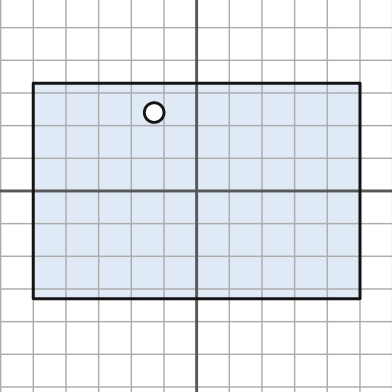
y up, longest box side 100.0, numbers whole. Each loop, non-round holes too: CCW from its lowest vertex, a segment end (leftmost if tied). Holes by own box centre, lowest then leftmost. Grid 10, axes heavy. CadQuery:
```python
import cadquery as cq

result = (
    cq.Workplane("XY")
    .moveTo(-50.0, -33.0)
    .lineTo(50.0, -33.0)
    .lineTo(50.0, 33.0)
    .lineTo(-50.0, 33.0)
    .close()
    .moveTo(-13.0, 24.0)
    .circle(3.0)
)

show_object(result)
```